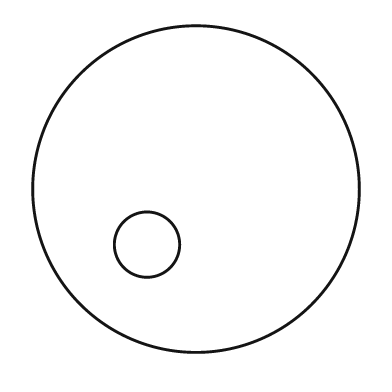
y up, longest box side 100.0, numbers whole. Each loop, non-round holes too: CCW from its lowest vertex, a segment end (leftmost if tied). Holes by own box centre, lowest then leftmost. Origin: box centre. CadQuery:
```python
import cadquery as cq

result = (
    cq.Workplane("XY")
    .moveTo(0.0, 0.0)
    .circle(50.0)
    .moveTo(-15.0, -17.0)
    .circle(10.0)
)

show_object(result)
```